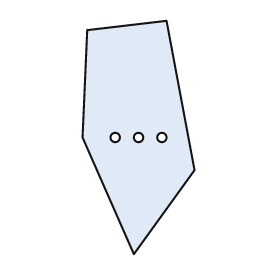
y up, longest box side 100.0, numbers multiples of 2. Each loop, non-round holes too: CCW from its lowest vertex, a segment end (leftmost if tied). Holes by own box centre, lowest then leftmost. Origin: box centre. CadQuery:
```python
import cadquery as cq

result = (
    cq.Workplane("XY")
    .moveTo(-2.0, -50.0)
    .lineTo(24.0, -14.0)
    .lineTo(12.0, 50.0)
    .lineTo(-22.0, 46.0)
    .lineTo(-24.0, 0.0)
    .close()
    .moveTo(-10.0, 0.0)
    .circle(2.0)
    .moveTo(0.0, 0.0)
    .circle(2.0)
    .moveTo(10.0, 0.0)
    .circle(2.0)
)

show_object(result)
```